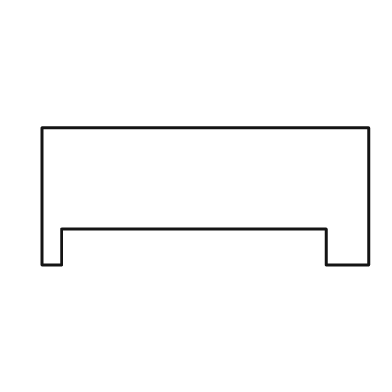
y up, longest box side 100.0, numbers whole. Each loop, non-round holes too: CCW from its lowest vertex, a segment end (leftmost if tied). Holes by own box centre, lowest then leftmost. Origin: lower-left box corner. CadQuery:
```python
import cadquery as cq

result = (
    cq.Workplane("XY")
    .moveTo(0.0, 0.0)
    .lineTo(6.0, 0.0)
    .lineTo(6.0, 11.0)
    .lineTo(87.0, 11.0)
    .lineTo(87.0, 0.0)
    .lineTo(100.0, 0.0)
    .lineTo(100.0, 42.0)
    .lineTo(0.0, 42.0)
    .close()
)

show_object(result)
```